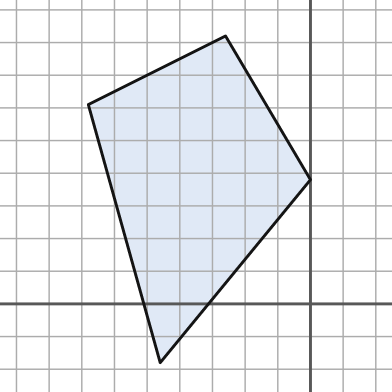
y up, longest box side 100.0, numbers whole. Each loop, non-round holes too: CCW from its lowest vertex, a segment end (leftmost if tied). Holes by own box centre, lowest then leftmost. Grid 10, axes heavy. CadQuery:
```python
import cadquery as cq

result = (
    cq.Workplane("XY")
    .moveTo(-46.0, -18.0)
    .lineTo(0.0, 38.0)
    .lineTo(-26.0, 82.0)
    .lineTo(-68.0, 61.0)
    .close()
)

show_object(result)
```